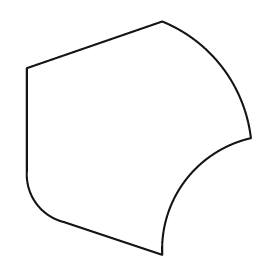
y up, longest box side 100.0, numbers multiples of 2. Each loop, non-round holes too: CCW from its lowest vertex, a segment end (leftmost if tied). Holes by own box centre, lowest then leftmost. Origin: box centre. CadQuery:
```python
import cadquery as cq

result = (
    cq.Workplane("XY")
    .moveTo(10.0, -50.0)
    .threePointArc((20.0, -18.0), (48.0, 0.0))
    .threePointArc((36.0, 30.0), (10.0, 50.0))
    .lineTo(-48.0, 30.0)
    .lineTo(-48.0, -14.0)
    .threePointArc((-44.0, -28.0), (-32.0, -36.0))
    .close()
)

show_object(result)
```